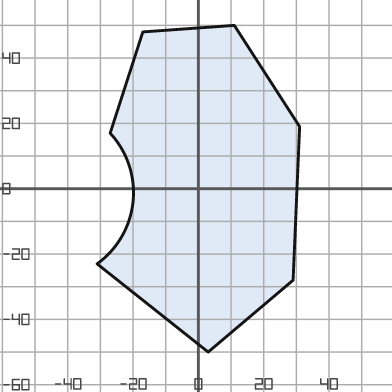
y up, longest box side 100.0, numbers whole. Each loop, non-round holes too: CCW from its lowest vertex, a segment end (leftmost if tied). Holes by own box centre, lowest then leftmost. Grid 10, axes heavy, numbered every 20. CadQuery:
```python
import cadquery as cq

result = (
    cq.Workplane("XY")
    .moveTo(3.0, -50.0)
    .lineTo(29.0, -28.0)
    .lineTo(31.0, 19.0)
    .lineTo(11.0, 50.0)
    .lineTo(-17.0, 48.0)
    .lineTo(-27.0, 17.0)
    .threePointArc((-20.0, -4.0), (-31.0, -23.0))
    .close()
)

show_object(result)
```